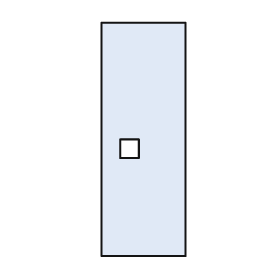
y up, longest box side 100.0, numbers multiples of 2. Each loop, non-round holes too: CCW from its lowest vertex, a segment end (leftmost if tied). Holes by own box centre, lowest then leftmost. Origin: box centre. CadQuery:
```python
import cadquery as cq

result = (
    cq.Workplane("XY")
    .moveTo(-18.0, -50.0)
    .lineTo(18.0, -50.0)
    .lineTo(18.0, 50.0)
    .lineTo(-18.0, 50.0)
    .close()
    .moveTo(-10.0, -8.0)
    .lineTo(-2.0, -8.0)
    .lineTo(-2.0, 0.0)
    .lineTo(-10.0, 0.0)
    .close()
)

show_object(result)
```